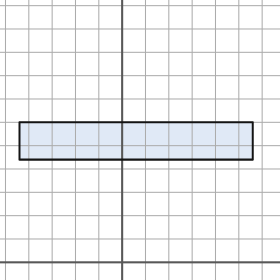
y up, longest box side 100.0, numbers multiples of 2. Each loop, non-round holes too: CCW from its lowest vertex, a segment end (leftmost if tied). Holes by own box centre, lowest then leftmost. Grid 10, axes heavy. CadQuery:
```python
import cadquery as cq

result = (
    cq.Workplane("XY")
    .moveTo(-44.0, 44.0)
    .lineTo(56.0, 44.0)
    .lineTo(56.0, 60.0)
    .lineTo(-44.0, 60.0)
    .close()
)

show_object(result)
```